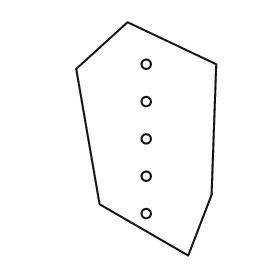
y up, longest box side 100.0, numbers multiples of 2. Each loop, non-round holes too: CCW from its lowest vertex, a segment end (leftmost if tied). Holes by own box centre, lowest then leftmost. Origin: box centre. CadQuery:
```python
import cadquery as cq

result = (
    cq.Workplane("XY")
    .moveTo(18.0, -50.0)
    .lineTo(28.0, -24.0)
    .lineTo(30.0, 32.0)
    .lineTo(-8.0, 50.0)
    .lineTo(-30.0, 30.0)
    .lineTo(-20.0, -28.0)
    .close()
    .moveTo(0.0, -32.0)
    .circle(2.0)
    .moveTo(0.0, -16.0)
    .circle(2.0)
    .moveTo(0.0, 0.0)
    .circle(2.0)
    .moveTo(0.0, 16.0)
    .circle(2.0)
    .moveTo(0.0, 32.0)
    .circle(2.0)
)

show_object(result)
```